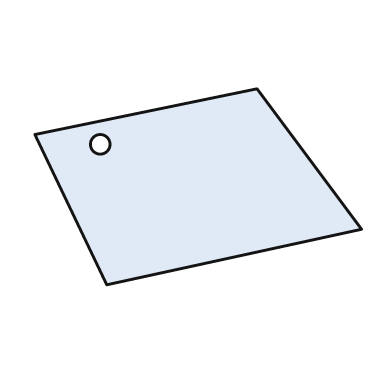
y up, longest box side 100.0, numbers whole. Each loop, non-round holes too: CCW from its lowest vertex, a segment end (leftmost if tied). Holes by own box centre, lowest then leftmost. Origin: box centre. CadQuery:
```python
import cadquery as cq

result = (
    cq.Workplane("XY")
    .moveTo(-28.0, -30.0)
    .lineTo(50.0, -13.0)
    .lineTo(18.0, 30.0)
    .lineTo(-50.0, 16.0)
    .close()
    .moveTo(-30.0, 13.0)
    .circle(3.0)
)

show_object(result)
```